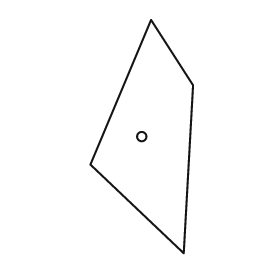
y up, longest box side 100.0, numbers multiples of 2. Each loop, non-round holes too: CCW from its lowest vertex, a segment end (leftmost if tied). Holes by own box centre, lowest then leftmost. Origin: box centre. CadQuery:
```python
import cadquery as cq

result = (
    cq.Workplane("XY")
    .moveTo(18.0, -50.0)
    .lineTo(22.0, 22.0)
    .lineTo(4.0, 50.0)
    .lineTo(-22.0, -12.0)
    .close()
    .moveTo(0.0, 0.0)
    .circle(2.0)
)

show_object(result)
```